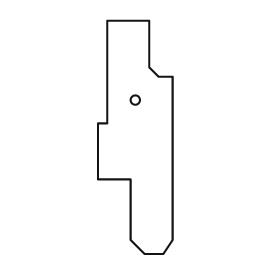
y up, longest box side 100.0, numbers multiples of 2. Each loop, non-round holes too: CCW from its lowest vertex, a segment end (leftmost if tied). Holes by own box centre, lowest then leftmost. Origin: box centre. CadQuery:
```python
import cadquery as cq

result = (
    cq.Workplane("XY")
    .moveTo(4.0, -50.0)
    .lineTo(12.0, -50.0)
    .lineTo(16.0, -44.0)
    .lineTo(16.0, 26.0)
    .lineTo(10.0, 26.0)
    .lineTo(6.0, 30.0)
    .lineTo(6.0, 50.0)
    .lineTo(-12.0, 50.0)
    .lineTo(-12.0, 6.0)
    .lineTo(-16.0, 6.0)
    .lineTo(-16.0, -18.0)
    .lineTo(-2.0, -18.0)
    .lineTo(-2.0, -44.0)
    .close()
    .moveTo(0.0, 16.0)
    .circle(2.0)
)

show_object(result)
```